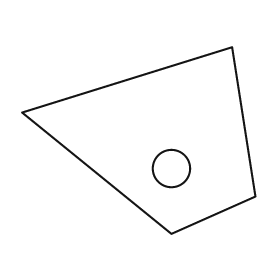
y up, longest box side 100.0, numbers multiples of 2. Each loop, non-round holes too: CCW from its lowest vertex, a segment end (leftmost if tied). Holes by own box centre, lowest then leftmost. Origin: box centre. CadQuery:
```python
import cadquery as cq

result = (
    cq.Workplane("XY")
    .moveTo(14.0, -40.0)
    .lineTo(50.0, -24.0)
    .lineTo(40.0, 40.0)
    .lineTo(-50.0, 12.0)
    .close()
    .moveTo(14.0, -12.0)
    .circle(8.0)
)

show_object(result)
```